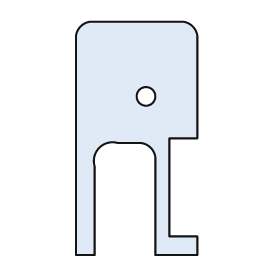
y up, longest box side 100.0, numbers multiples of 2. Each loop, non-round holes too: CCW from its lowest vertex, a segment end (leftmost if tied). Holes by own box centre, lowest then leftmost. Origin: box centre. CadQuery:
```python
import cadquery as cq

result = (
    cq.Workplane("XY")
    .moveTo(-26.0, -50.0)
    .lineTo(-18.0, -50.0)
    .lineTo(-18.0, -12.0)
    .threePointArc((-16.0, -4.0), (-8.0, -2.0))
    .lineTo(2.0, -2.0)
    .threePointArc((6.0, -4.0), (8.0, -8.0))
    .lineTo(8.0, -50.0)
    .lineTo(26.0, -50.0)
    .lineTo(26.0, -42.0)
    .lineTo(14.0, -42.0)
    .lineTo(14.0, 0.0)
    .lineTo(26.0, 0.0)
    .lineTo(26.0, 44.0)
    .threePointArc((24.0, 48.0), (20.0, 50.0))
    .lineTo(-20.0, 50.0)
    .threePointArc((-24.0, 48.0), (-26.0, 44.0))
    .close()
    .moveTo(4.0, 18.0)
    .circle(4.0)
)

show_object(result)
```